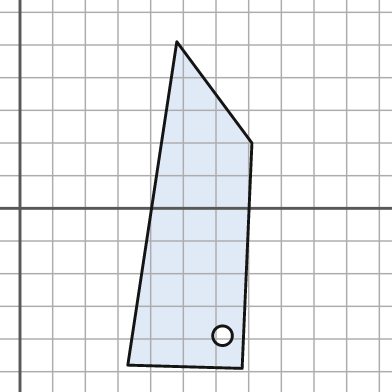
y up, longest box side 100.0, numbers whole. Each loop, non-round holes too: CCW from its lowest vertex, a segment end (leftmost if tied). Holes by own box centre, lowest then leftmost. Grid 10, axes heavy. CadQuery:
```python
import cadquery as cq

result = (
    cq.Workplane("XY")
    .moveTo(68.0, -49.0)
    .lineTo(71.0, 20.0)
    .lineTo(48.0, 51.0)
    .lineTo(33.0, -48.0)
    .close()
    .moveTo(62.0, -39.0)
    .circle(3.0)
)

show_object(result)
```